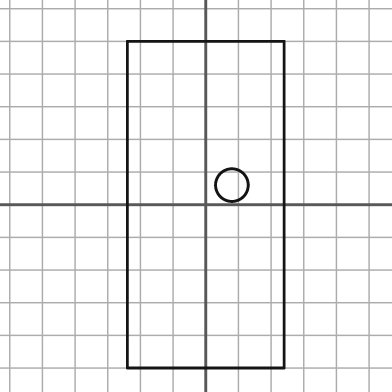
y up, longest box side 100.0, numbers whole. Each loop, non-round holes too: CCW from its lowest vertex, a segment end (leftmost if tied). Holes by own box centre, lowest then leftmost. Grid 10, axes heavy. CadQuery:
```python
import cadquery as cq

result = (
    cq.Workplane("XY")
    .moveTo(-24.0, -50.0)
    .lineTo(24.0, -50.0)
    .lineTo(24.0, 50.0)
    .lineTo(-24.0, 50.0)
    .close()
    .moveTo(8.0, 6.0)
    .circle(5.0)
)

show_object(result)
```